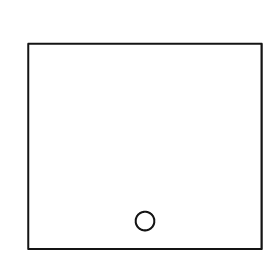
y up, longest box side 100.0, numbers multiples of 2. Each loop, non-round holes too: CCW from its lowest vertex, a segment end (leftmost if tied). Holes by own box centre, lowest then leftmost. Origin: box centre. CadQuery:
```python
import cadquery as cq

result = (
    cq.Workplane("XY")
    .moveTo(-50.0, -44.0)
    .lineTo(50.0, -44.0)
    .lineTo(50.0, 44.0)
    .lineTo(-50.0, 44.0)
    .close()
    .moveTo(0.0, -32.0)
    .circle(4.0)
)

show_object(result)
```